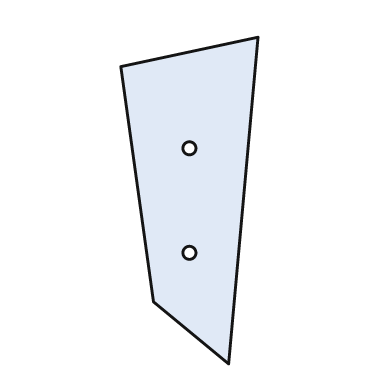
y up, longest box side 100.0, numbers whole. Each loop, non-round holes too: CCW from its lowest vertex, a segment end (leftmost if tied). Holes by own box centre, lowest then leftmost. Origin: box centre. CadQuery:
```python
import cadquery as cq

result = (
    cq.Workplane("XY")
    .moveTo(12.0, -50.0)
    .lineTo(21.0, 50.0)
    .lineTo(-21.0, 41.0)
    .lineTo(-11.0, -31.0)
    .close()
    .moveTo(0.0, -16.0)
    .circle(2.0)
    .moveTo(0.0, 16.0)
    .circle(2.0)
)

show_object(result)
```